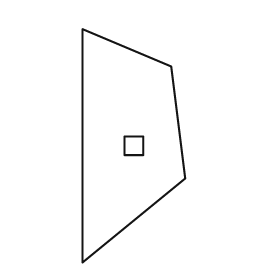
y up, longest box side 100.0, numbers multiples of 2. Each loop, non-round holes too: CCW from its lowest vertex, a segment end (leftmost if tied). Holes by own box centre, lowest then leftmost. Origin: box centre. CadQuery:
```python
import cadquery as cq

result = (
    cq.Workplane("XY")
    .moveTo(-22.0, -50.0)
    .lineTo(22.0, -14.0)
    .lineTo(16.0, 34.0)
    .lineTo(-22.0, 50.0)
    .close()
    .moveTo(-4.0, -4.0)
    .lineTo(4.0, -4.0)
    .lineTo(4.0, 4.0)
    .lineTo(-4.0, 4.0)
    .close()
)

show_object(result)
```